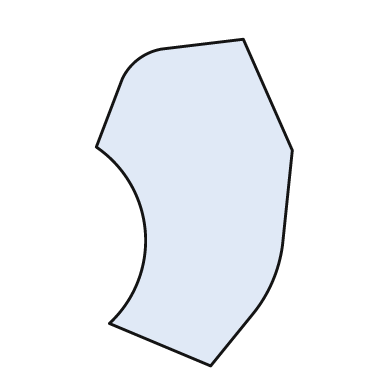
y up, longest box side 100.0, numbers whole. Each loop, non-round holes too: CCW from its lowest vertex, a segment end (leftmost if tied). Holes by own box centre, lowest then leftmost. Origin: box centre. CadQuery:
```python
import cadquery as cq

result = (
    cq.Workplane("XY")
    .moveTo(5.0, -50.0)
    .lineTo(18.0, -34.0)
    .threePointArc((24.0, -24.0), (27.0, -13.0))
    .lineTo(30.0, 16.0)
    .lineTo(15.0, 50.0)
    .lineTo(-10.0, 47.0)
    .threePointArc((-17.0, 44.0), (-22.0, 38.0))
    .lineTo(-30.0, 17.0)
    .threePointArc((-15.0, -9.0), (-26.0, -37.0))
    .close()
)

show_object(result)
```